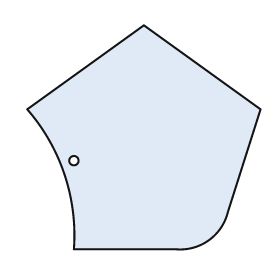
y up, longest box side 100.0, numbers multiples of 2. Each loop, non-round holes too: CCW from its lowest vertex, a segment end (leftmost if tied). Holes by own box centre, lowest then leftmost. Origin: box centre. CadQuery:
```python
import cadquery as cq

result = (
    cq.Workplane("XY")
    .moveTo(-30.0, -48.0)
    .lineTo(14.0, -48.0)
    .threePointArc((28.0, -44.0), (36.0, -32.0))
    .lineTo(50.0, 12.0)
    .lineTo(0.0, 48.0)
    .lineTo(-50.0, 12.0)
    .threePointArc((-34.0, -16.0), (-30.0, -48.0))
    .close()
    .moveTo(-30.0, -10.0)
    .circle(2.0)
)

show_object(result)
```